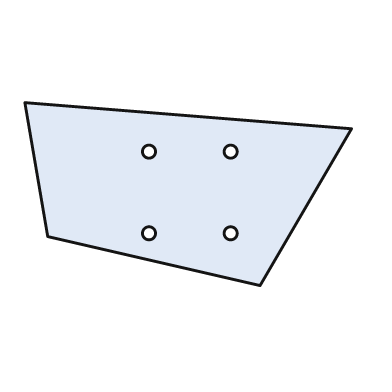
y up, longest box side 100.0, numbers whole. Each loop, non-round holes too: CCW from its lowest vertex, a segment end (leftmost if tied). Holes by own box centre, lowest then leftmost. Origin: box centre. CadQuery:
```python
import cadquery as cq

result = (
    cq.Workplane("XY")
    .moveTo(22.0, -28.0)
    .lineTo(50.0, 20.0)
    .lineTo(-50.0, 28.0)
    .lineTo(-43.0, -13.0)
    .close()
    .moveTo(-12.0, -12.0)
    .circle(2.0)
    .moveTo(13.0, -12.0)
    .circle(2.0)
    .moveTo(-12.0, 13.0)
    .circle(2.0)
    .moveTo(13.0, 13.0)
    .circle(2.0)
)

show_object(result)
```